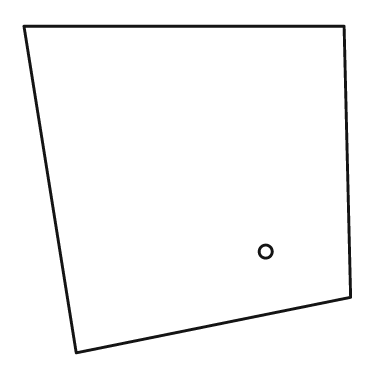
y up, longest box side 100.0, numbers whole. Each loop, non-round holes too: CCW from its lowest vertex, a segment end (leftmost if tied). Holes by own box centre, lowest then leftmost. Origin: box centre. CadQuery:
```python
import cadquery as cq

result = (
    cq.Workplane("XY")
    .moveTo(-34.0, -50.0)
    .lineTo(50.0, -33.0)
    .lineTo(48.0, 50.0)
    .lineTo(-50.0, 50.0)
    .close()
    .moveTo(24.0, -19.0)
    .circle(2.0)
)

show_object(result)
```